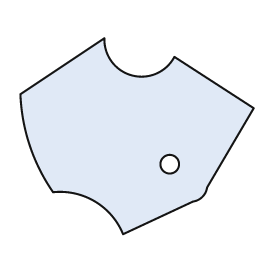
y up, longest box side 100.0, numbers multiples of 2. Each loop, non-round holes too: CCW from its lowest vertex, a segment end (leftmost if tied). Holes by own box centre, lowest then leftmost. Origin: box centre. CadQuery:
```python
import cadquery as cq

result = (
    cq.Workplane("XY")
    .moveTo(-6.0, -42.0)
    .lineTo(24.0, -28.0)
    .threePointArc((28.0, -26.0), (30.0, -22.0))
    .lineTo(50.0, 12.0)
    .lineTo(16.0, 34.0)
    .threePointArc((-2.0, 26.0), (-14.0, 42.0))
    .lineTo(-50.0, 18.0)
    .threePointArc((-46.0, -4.0), (-36.0, -24.0))
    .threePointArc((-18.0, -28.0), (-6.0, -42.0))
    .close()
    .moveTo(14.0, -12.0)
    .circle(4.0)
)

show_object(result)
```